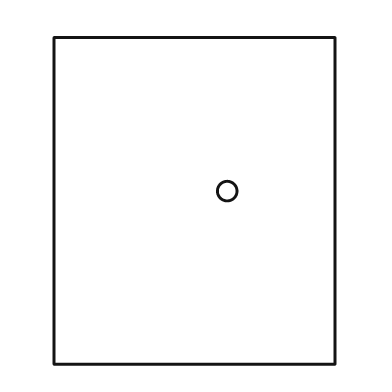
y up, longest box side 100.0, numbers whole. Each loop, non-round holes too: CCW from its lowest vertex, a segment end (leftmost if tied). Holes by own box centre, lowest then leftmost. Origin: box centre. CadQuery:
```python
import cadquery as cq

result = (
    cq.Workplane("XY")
    .moveTo(-43.0, -50.0)
    .lineTo(43.0, -50.0)
    .lineTo(43.0, 50.0)
    .lineTo(-43.0, 50.0)
    .close()
    .moveTo(10.0, 3.0)
    .circle(3.0)
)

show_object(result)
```